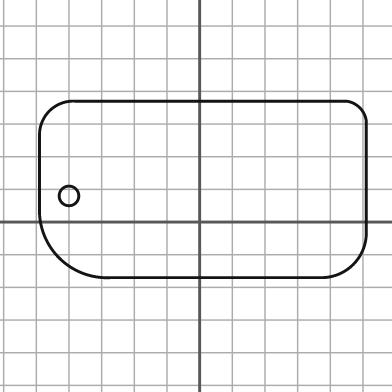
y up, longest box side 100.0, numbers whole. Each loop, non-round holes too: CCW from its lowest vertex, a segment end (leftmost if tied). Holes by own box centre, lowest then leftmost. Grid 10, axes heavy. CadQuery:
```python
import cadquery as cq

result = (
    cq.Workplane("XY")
    .moveTo(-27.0, -17.0)
    .lineTo(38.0, -17.0)
    .threePointArc((47.0, -13.0), (51.0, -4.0))
    .lineTo(51.0, 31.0)
    .threePointArc((49.0, 35.0), (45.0, 37.0))
    .lineTo(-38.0, 37.0)
    .threePointArc((-46.0, 34.0), (-49.0, 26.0))
    .lineTo(-49.0, 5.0)
    .threePointArc((-43.0, -11.0), (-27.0, -17.0))
    .close()
    .moveTo(-40.0, 8.0)
    .circle(3.0)
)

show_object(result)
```